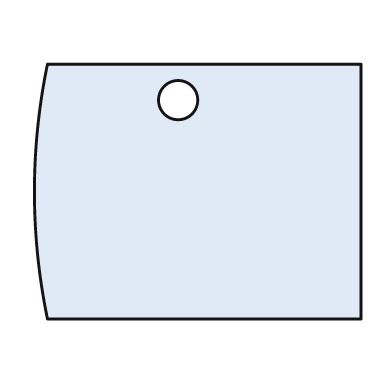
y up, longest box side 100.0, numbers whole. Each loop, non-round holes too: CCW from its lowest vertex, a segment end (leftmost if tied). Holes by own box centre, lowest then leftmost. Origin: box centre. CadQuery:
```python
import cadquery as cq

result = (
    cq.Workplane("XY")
    .moveTo(-46.0, -39.0)
    .lineTo(50.0, -39.0)
    .lineTo(50.0, 39.0)
    .lineTo(-46.0, 39.0)
    .threePointArc((-50.0, 0.0), (-46.0, -39.0))
    .close()
    .moveTo(-6.0, 28.0)
    .circle(6.0)
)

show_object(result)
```